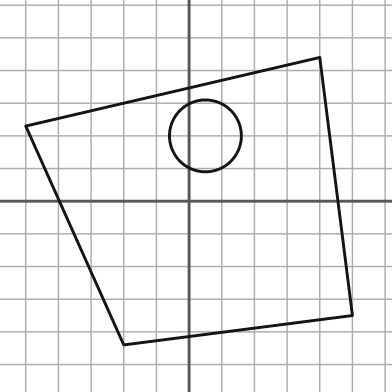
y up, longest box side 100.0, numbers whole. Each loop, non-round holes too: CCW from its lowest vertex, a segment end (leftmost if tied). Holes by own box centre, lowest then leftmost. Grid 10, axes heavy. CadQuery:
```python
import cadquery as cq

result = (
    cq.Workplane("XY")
    .moveTo(-20.0, -44.0)
    .lineTo(50.0, -35.0)
    .lineTo(40.0, 44.0)
    .lineTo(-50.0, 23.0)
    .close()
    .moveTo(5.0, 20.0)
    .circle(11.0)
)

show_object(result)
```